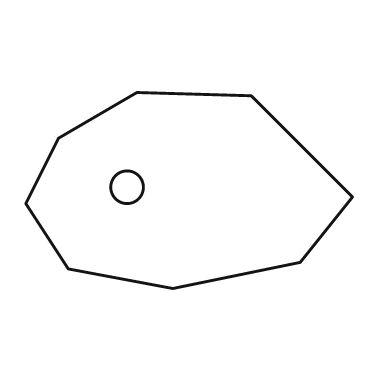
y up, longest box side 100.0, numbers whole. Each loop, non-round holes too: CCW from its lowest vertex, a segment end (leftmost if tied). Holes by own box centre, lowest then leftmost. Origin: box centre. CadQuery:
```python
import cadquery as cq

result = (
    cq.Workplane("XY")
    .moveTo(-5.0, -30.0)
    .lineTo(34.0, -22.0)
    .lineTo(50.0, -2.0)
    .lineTo(19.0, 29.0)
    .lineTo(-16.0, 30.0)
    .lineTo(-40.0, 16.0)
    .lineTo(-50.0, -4.0)
    .lineTo(-37.0, -24.0)
    .close()
    .moveTo(-19.0, 1.0)
    .circle(5.0)
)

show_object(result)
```